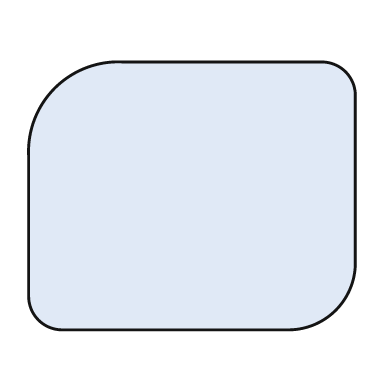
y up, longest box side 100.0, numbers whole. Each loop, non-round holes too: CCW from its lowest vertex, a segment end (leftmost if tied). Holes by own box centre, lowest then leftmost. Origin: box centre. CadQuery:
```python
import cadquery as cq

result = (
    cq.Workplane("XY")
    .moveTo(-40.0, -41.0)
    .lineTo(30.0, -41.0)
    .threePointArc((44.0, -35.0), (50.0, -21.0))
    .lineTo(50.0, 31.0)
    .threePointArc((47.0, 38.0), (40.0, 41.0))
    .lineTo(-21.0, 41.0)
    .threePointArc((-42.0, 33.0), (-50.0, 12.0))
    .lineTo(-50.0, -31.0)
    .threePointArc((-47.0, -38.0), (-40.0, -41.0))
    .close()
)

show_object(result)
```